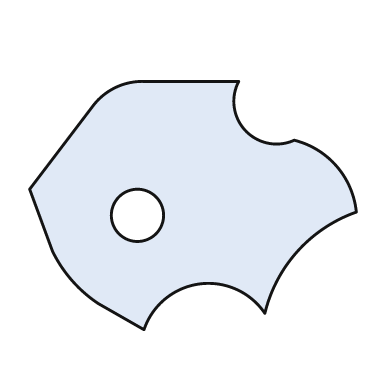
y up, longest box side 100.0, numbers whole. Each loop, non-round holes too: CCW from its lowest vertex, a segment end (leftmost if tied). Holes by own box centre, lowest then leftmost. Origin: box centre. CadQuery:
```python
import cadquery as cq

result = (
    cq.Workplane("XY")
    .moveTo(-15.0, -38.0)
    .threePointArc((2.0, -24.0), (22.0, -33.0))
    .threePointArc((32.0, -14.0), (50.0, -2.0))
    .threePointArc((44.0, 12.0), (31.0, 20.0))
    .threePointArc((16.0, 23.0), (14.0, 38.0))
    .lineTo(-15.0, 38.0)
    .threePointArc((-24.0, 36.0), (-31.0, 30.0))
    .lineTo(-50.0, 5.0)
    .lineTo(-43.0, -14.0)
    .threePointArc((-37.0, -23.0), (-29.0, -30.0))
    .close()
    .moveTo(-17.0, -3.0)
    .circle(8.0)
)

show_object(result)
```